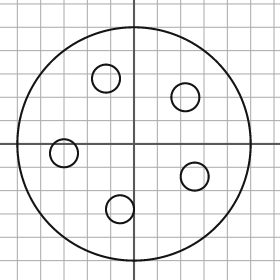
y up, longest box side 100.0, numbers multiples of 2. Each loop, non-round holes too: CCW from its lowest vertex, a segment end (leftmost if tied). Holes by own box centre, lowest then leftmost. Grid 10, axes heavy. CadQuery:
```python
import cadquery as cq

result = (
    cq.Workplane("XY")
    .moveTo(0.0, 0.0)
    .circle(50.0)
    .moveTo(-6.0, -28.0)
    .circle(6.0)
    .moveTo(26.0, -14.0)
    .circle(6.0)
    .moveTo(-30.0, -4.0)
    .circle(6.0)
    .moveTo(22.0, 20.0)
    .circle(6.0)
    .moveTo(-12.0, 28.0)
    .circle(6.0)
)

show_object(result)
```